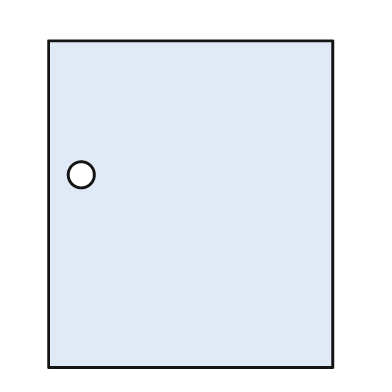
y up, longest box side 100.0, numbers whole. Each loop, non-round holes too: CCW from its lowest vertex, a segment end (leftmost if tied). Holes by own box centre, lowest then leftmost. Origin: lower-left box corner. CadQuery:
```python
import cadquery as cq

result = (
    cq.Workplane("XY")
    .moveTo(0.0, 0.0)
    .lineTo(87.0, 0.0)
    .lineTo(87.0, 100.0)
    .lineTo(0.0, 100.0)
    .close()
    .moveTo(10.0, 59.0)
    .circle(4.0)
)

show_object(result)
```